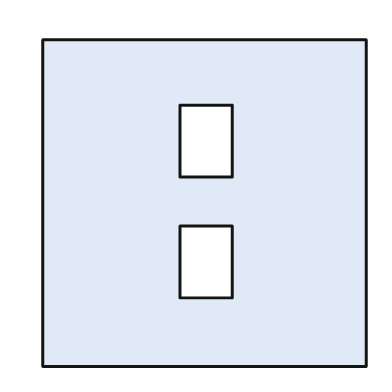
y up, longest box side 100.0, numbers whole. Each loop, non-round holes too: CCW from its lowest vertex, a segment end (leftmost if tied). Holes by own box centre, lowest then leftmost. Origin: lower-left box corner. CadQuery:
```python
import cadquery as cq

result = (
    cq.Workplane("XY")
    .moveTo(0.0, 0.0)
    .lineTo(99.0, 0.0)
    .lineTo(99.0, 100.0)
    .lineTo(0.0, 100.0)
    .close()
    .moveTo(42.0, 21.0)
    .lineTo(58.0, 21.0)
    .lineTo(58.0, 43.0)
    .lineTo(42.0, 43.0)
    .close()
    .moveTo(42.0, 58.0)
    .lineTo(58.0, 58.0)
    .lineTo(58.0, 80.0)
    .lineTo(42.0, 80.0)
    .close()
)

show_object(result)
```